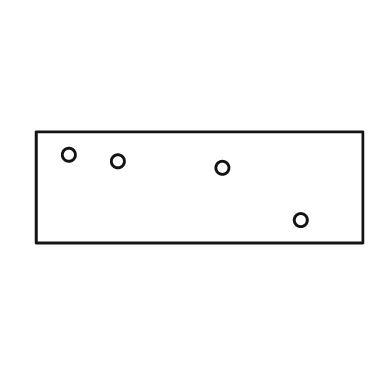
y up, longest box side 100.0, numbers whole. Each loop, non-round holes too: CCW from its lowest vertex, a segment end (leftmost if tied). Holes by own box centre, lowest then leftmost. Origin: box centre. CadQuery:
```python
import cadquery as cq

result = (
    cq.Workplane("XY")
    .moveTo(-50.0, -17.0)
    .lineTo(50.0, -17.0)
    .lineTo(50.0, 17.0)
    .lineTo(-50.0, 17.0)
    .close()
    .moveTo(31.0, -10.0)
    .circle(2.0)
    .moveTo(7.0, 6.0)
    .circle(2.0)
    .moveTo(-25.0, 8.0)
    .circle(2.0)
    .moveTo(-40.0, 10.0)
    .circle(2.0)
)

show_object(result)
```